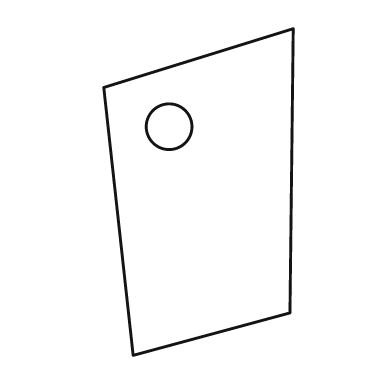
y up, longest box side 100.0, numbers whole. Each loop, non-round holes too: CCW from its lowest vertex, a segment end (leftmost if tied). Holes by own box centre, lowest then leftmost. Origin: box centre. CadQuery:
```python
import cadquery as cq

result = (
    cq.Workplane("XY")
    .moveTo(-20.0, -50.0)
    .lineTo(28.0, -37.0)
    .lineTo(29.0, 50.0)
    .lineTo(-29.0, 32.0)
    .close()
    .moveTo(-9.0, 20.0)
    .circle(7.0)
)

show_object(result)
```